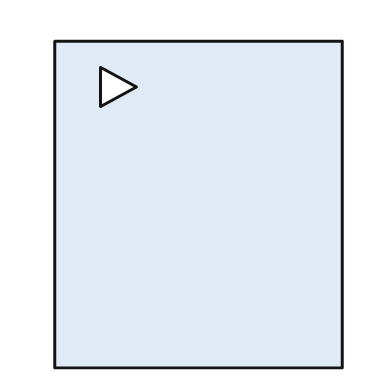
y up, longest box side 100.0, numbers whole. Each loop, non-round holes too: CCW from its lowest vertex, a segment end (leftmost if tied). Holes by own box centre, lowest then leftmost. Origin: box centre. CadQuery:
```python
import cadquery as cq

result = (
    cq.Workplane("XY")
    .moveTo(-44.0, -50.0)
    .lineTo(44.0, -50.0)
    .lineTo(44.0, 50.0)
    .lineTo(-44.0, 50.0)
    .close()
    .moveTo(-30.0, 30.0)
    .lineTo(-19.0, 36.0)
    .lineTo(-30.0, 42.0)
    .close()
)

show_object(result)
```